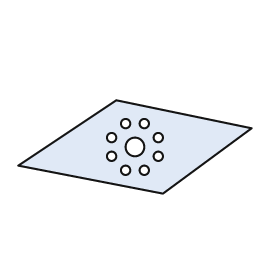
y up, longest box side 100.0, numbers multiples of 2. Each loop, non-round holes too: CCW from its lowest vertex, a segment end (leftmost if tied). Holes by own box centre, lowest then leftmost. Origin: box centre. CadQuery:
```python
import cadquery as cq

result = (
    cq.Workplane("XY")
    .moveTo(12.0, -20.0)
    .lineTo(50.0, 8.0)
    .lineTo(-8.0, 20.0)
    .lineTo(-50.0, -8.0)
    .close()
    .moveTo(-4.0, -10.0)
    .circle(2.0)
    .moveTo(4.0, -10.0)
    .circle(2.0)
    .moveTo(-10.0, -4.0)
    .circle(2.0)
    .moveTo(10.0, -4.0)
    .circle(2.0)
    .moveTo(0.0, 0.0)
    .circle(4.0)
    .moveTo(-10.0, 4.0)
    .circle(2.0)
    .moveTo(10.0, 4.0)
    .circle(2.0)
    .moveTo(-4.0, 10.0)
    .circle(2.0)
    .moveTo(4.0, 10.0)
    .circle(2.0)
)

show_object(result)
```